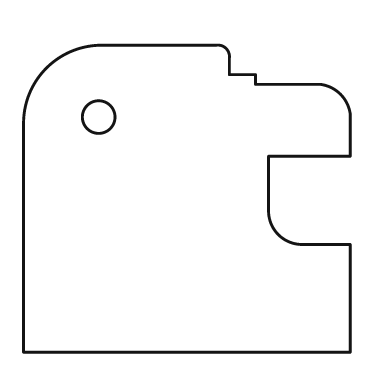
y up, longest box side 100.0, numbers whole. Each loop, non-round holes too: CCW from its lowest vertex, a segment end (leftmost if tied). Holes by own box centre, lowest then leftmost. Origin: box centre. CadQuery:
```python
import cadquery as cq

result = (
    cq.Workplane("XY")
    .moveTo(-50.0, -47.0)
    .lineTo(50.0, -47.0)
    .lineTo(50.0, -14.0)
    .lineTo(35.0, -14.0)
    .threePointArc((28.0, -11.0), (25.0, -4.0))
    .lineTo(25.0, 13.0)
    .lineTo(50.0, 13.0)
    .lineTo(50.0, 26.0)
    .threePointArc((47.0, 32.0), (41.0, 35.0))
    .lineTo(21.0, 35.0)
    .lineTo(21.0, 38.0)
    .lineTo(13.0, 38.0)
    .lineTo(13.0, 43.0)
    .threePointArc((12.0, 46.0), (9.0, 47.0))
    .lineTo(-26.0, 47.0)
    .threePointArc((-43.0, 40.0), (-50.0, 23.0))
    .close()
    .moveTo(-27.0, 25.0)
    .circle(5.0)
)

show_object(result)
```